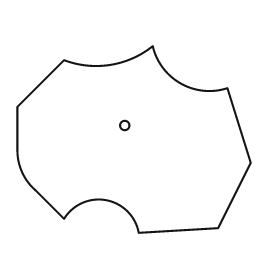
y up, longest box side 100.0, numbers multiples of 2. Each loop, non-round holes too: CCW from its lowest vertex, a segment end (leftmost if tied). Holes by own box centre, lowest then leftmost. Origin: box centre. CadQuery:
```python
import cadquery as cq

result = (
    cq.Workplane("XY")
    .moveTo(2.0, -40.0)
    .lineTo(36.0, -38.0)
    .lineTo(50.0, -10.0)
    .lineTo(40.0, 22.0)
    .threePointArc((20.0, 24.0), (8.0, 40.0))
    .threePointArc((-10.0, 32.0), (-30.0, 34.0))
    .lineTo(-50.0, 14.0)
    .lineTo(-50.0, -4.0)
    .threePointArc((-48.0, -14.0), (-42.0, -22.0))
    .lineTo(-30.0, -34.0)
    .threePointArc((-12.0, -26.0), (2.0, -40.0))
    .close()
    .moveTo(-4.0, 6.0)
    .circle(2.0)
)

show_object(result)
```